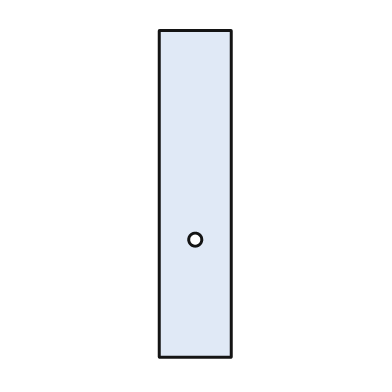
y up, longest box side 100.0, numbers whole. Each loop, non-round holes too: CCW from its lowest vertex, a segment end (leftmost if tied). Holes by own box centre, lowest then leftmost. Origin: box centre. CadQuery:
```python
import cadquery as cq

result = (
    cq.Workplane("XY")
    .moveTo(-11.0, -50.0)
    .lineTo(11.0, -50.0)
    .lineTo(11.0, 50.0)
    .lineTo(-11.0, 50.0)
    .close()
    .moveTo(0.0, -14.0)
    .circle(2.0)
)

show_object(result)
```